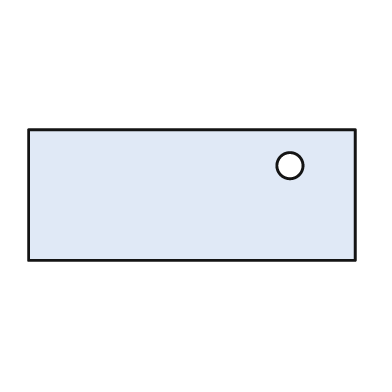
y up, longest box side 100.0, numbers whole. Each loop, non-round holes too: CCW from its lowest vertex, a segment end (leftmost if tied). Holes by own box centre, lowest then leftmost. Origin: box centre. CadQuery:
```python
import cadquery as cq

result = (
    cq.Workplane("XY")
    .moveTo(-50.0, -20.0)
    .lineTo(50.0, -20.0)
    .lineTo(50.0, 20.0)
    .lineTo(-50.0, 20.0)
    .close()
    .moveTo(30.0, 9.0)
    .circle(4.0)
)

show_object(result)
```